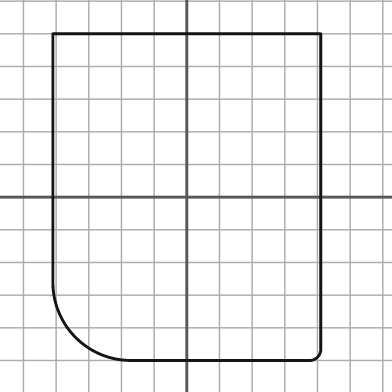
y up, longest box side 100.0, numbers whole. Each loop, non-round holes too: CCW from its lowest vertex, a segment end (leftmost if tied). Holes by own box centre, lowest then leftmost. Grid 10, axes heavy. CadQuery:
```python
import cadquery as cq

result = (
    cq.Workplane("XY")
    .moveTo(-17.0, -50.0)
    .lineTo(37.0, -50.0)
    .threePointArc((40.0, -49.0), (41.0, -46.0))
    .lineTo(41.0, 50.0)
    .lineTo(-41.0, 50.0)
    .lineTo(-41.0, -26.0)
    .threePointArc((-34.0, -43.0), (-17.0, -50.0))
    .close()
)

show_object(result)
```